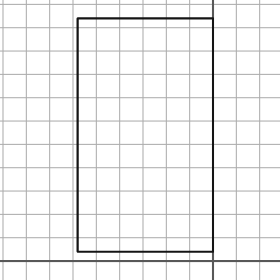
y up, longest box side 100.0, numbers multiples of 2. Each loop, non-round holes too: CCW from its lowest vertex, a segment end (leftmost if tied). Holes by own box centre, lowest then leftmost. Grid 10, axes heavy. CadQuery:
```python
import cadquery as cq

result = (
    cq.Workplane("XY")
    .moveTo(-58.0, 4.0)
    .lineTo(0.0, 4.0)
    .lineTo(0.0, 104.0)
    .lineTo(-58.0, 104.0)
    .close()
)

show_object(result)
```